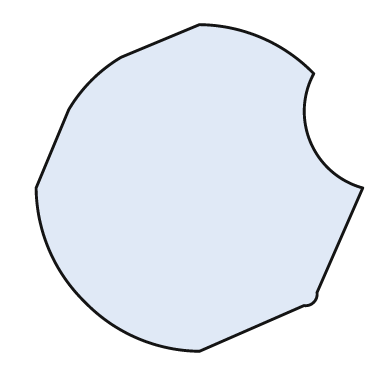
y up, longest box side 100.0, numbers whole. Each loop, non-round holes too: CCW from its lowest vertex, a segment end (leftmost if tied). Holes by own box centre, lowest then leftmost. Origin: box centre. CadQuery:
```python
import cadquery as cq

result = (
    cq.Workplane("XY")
    .moveTo(0.0, -50.0)
    .lineTo(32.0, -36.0)
    .threePointArc((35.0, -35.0), (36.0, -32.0))
    .lineTo(50.0, 0.0)
    .threePointArc((34.0, 14.0), (35.0, 35.0))
    .threePointArc((19.0, 46.0), (0.0, 50.0))
    .lineTo(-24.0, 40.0)
    .threePointArc((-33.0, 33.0), (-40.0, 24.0))
    .lineTo(-50.0, 0.0)
    .threePointArc((-46.0, -19.0), (-35.0, -35.0))
    .threePointArc((-19.0, -46.0), (0.0, -50.0))
    .close()
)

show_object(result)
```